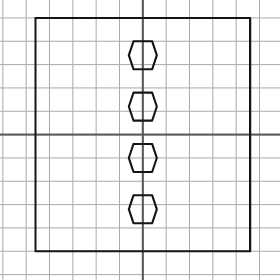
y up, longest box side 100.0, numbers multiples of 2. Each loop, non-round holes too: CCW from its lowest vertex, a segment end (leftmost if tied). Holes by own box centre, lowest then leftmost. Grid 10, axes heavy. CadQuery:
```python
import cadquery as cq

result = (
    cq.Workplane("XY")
    .moveTo(-46.0, -50.0)
    .lineTo(46.0, -50.0)
    .lineTo(46.0, 50.0)
    .lineTo(-46.0, 50.0)
    .close()
    .moveTo(-4.0, -38.0)
    .lineTo(4.0, -38.0)
    .lineTo(6.0, -32.0)
    .lineTo(4.0, -26.0)
    .lineTo(-4.0, -26.0)
    .lineTo(-6.0, -32.0)
    .close()
    .moveTo(-4.0, -16.0)
    .lineTo(4.0, -16.0)
    .lineTo(6.0, -10.0)
    .lineTo(4.0, -4.0)
    .lineTo(-4.0, -4.0)
    .lineTo(-6.0, -10.0)
    .close()
    .moveTo(-4.0, 6.0)
    .lineTo(4.0, 6.0)
    .lineTo(6.0, 12.0)
    .lineTo(4.0, 18.0)
    .lineTo(-4.0, 18.0)
    .lineTo(-6.0, 12.0)
    .close()
    .moveTo(-4.0, 28.0)
    .lineTo(4.0, 28.0)
    .lineTo(6.0, 34.0)
    .lineTo(4.0, 40.0)
    .lineTo(-4.0, 40.0)
    .lineTo(-6.0, 34.0)
    .close()
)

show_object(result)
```